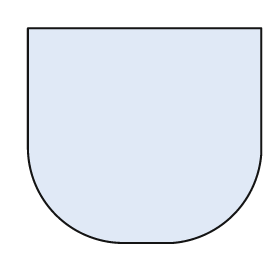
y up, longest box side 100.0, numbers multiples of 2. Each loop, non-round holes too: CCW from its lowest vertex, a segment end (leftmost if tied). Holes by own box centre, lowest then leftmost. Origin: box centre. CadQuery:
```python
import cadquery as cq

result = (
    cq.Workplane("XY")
    .moveTo(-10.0, -46.0)
    .lineTo(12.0, -46.0)
    .threePointArc((38.0, -34.0), (50.0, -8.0))
    .lineTo(50.0, 46.0)
    .lineTo(-50.0, 46.0)
    .lineTo(-50.0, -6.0)
    .threePointArc((-38.0, -34.0), (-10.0, -46.0))
    .close()
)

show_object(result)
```